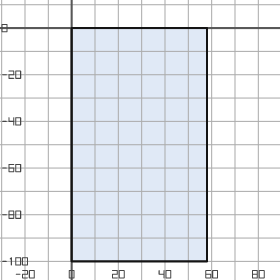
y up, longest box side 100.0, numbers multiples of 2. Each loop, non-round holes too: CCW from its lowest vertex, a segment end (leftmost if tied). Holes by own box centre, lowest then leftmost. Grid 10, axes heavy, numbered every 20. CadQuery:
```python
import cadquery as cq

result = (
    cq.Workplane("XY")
    .moveTo(0.0, -100.0)
    .lineTo(58.0, -100.0)
    .lineTo(58.0, 0.0)
    .lineTo(0.0, 0.0)
    .close()
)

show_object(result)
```